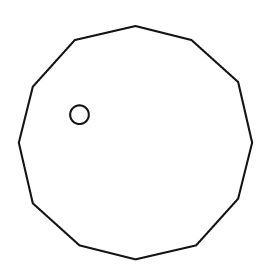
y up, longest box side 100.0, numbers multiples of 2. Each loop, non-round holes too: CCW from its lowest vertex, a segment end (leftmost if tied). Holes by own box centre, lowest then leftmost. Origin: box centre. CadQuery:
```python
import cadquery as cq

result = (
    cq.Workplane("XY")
    .moveTo(0.0, -50.0)
    .lineTo(26.0, -44.0)
    .lineTo(44.0, -24.0)
    .lineTo(50.0, 0.0)
    .lineTo(44.0, 26.0)
    .lineTo(24.0, 44.0)
    .lineTo(0.0, 50.0)
    .lineTo(-26.0, 44.0)
    .lineTo(-44.0, 24.0)
    .lineTo(-50.0, 0.0)
    .lineTo(-44.0, -26.0)
    .lineTo(-24.0, -44.0)
    .close()
    .moveTo(-24.0, 12.0)
    .circle(4.0)
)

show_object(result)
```